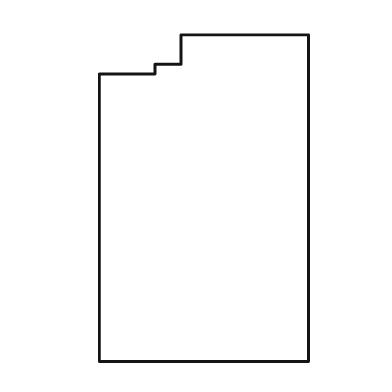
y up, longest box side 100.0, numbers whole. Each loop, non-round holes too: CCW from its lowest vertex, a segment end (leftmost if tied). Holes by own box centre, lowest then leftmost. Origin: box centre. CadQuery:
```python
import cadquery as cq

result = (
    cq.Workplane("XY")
    .moveTo(-32.0, -50.0)
    .lineTo(32.0, -50.0)
    .lineTo(32.0, 50.0)
    .lineTo(-7.0, 50.0)
    .lineTo(-7.0, 41.0)
    .lineTo(-15.0, 41.0)
    .lineTo(-15.0, 38.0)
    .lineTo(-32.0, 38.0)
    .close()
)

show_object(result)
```